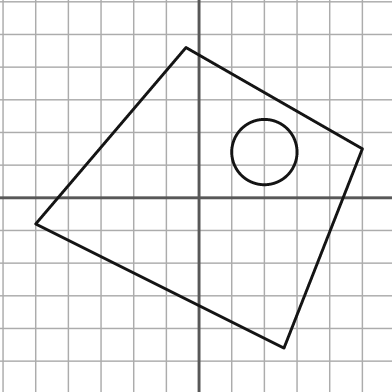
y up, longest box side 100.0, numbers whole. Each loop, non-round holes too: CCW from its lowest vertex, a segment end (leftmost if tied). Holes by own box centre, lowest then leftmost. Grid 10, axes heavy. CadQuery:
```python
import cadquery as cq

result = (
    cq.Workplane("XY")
    .moveTo(26.0, -46.0)
    .lineTo(50.0, 15.0)
    .lineTo(-4.0, 46.0)
    .lineTo(-50.0, -8.0)
    .close()
    .moveTo(20.0, 14.0)
    .circle(10.0)
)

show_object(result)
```